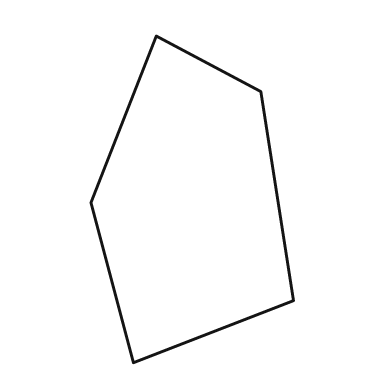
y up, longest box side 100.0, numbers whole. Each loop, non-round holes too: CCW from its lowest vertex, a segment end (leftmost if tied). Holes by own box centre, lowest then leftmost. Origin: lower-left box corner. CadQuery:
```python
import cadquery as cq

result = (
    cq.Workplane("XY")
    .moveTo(13.0, 0.0)
    .lineTo(62.0, 19.0)
    .lineTo(52.0, 83.0)
    .lineTo(20.0, 100.0)
    .lineTo(0.0, 49.0)
    .close()
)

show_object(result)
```